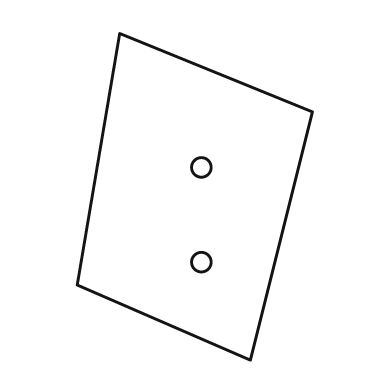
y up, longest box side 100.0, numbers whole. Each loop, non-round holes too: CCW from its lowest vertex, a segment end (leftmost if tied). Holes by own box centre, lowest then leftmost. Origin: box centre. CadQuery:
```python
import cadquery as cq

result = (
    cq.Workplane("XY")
    .moveTo(17.0, -50.0)
    .lineTo(36.0, 26.0)
    .lineTo(-23.0, 50.0)
    .lineTo(-36.0, -27.0)
    .close()
    .moveTo(2.0, -20.0)
    .circle(3.0)
    .moveTo(2.0, 9.0)
    .circle(3.0)
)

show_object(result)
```